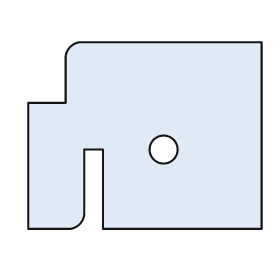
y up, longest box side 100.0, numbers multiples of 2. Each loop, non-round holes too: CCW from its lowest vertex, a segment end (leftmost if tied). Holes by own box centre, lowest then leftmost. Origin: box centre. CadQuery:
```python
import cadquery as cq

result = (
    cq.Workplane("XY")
    .moveTo(-50.0, -40.0)
    .lineTo(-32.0, -40.0)
    .threePointArc((-28.0, -38.0), (-26.0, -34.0))
    .lineTo(-26.0, -6.0)
    .lineTo(-18.0, -6.0)
    .lineTo(-18.0, -40.0)
    .lineTo(50.0, -40.0)
    .lineTo(50.0, 40.0)
    .lineTo(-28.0, 40.0)
    .threePointArc((-32.0, 38.0), (-34.0, 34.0))
    .lineTo(-34.0, 14.0)
    .lineTo(-50.0, 14.0)
    .close()
    .moveTo(8.0, -6.0)
    .circle(6.0)
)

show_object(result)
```